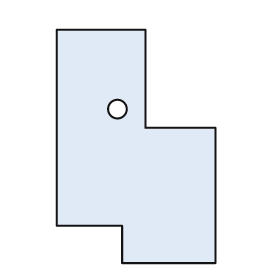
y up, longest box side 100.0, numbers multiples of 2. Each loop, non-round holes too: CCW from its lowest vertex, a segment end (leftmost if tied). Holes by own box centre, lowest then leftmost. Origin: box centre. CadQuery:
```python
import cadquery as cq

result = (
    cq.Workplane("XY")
    .moveTo(-6.0, -50.0)
    .lineTo(34.0, -50.0)
    .lineTo(34.0, 8.0)
    .lineTo(4.0, 8.0)
    .lineTo(4.0, 50.0)
    .lineTo(-34.0, 50.0)
    .lineTo(-34.0, -34.0)
    .lineTo(-6.0, -34.0)
    .close()
    .moveTo(-8.0, 16.0)
    .circle(4.0)
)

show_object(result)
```